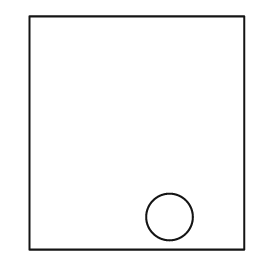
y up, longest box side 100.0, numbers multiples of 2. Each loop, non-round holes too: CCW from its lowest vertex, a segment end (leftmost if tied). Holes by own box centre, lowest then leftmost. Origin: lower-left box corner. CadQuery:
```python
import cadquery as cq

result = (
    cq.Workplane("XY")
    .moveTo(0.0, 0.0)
    .lineTo(92.0, 0.0)
    .lineTo(92.0, 100.0)
    .lineTo(0.0, 100.0)
    .close()
    .moveTo(60.0, 14.0)
    .circle(10.0)
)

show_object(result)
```